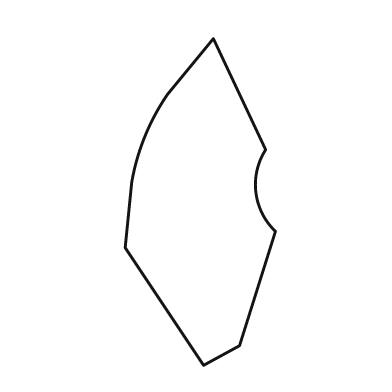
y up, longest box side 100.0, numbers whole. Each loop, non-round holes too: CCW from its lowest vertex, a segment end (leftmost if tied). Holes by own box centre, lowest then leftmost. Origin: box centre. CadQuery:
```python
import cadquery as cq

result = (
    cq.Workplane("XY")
    .moveTo(1.0, -50.0)
    .lineTo(12.0, -44.0)
    .lineTo(23.0, -9.0)
    .threePointArc((17.0, 3.0), (20.0, 16.0))
    .lineTo(4.0, 50.0)
    .lineTo(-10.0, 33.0)
    .threePointArc((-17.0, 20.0), (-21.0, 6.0))
    .lineTo(-23.0, -14.0)
    .close()
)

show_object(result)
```